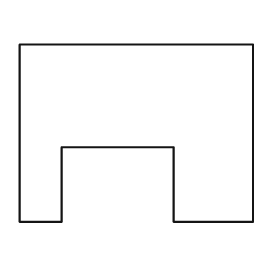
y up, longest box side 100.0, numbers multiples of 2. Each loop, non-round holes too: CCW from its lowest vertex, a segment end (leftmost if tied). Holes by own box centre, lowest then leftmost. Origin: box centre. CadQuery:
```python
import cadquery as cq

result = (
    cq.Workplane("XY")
    .moveTo(-50.0, -38.0)
    .lineTo(-32.0, -38.0)
    .lineTo(-32.0, -6.0)
    .lineTo(16.0, -6.0)
    .lineTo(16.0, -38.0)
    .lineTo(50.0, -38.0)
    .lineTo(50.0, 38.0)
    .lineTo(-50.0, 38.0)
    .close()
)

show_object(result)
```